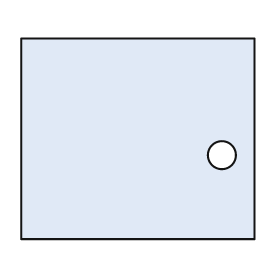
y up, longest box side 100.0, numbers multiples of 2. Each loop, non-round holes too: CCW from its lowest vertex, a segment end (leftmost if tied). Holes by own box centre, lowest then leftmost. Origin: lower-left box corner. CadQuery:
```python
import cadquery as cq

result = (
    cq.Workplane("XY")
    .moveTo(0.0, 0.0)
    .lineTo(100.0, 0.0)
    .lineTo(100.0, 86.0)
    .lineTo(0.0, 86.0)
    .close()
    .moveTo(86.0, 36.0)
    .circle(6.0)
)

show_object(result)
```